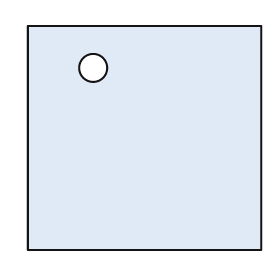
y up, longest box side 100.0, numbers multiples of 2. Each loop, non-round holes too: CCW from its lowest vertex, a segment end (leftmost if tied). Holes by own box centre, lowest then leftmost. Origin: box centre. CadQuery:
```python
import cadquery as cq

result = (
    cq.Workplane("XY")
    .moveTo(-50.0, -48.0)
    .lineTo(50.0, -48.0)
    .lineTo(50.0, 48.0)
    .lineTo(-50.0, 48.0)
    .close()
    .moveTo(-22.0, 30.0)
    .circle(6.0)
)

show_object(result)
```